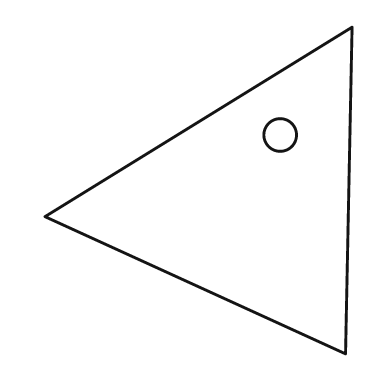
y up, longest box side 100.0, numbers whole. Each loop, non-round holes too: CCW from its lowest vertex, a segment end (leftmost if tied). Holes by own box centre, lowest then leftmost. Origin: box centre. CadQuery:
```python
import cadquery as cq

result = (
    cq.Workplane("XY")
    .moveTo(45.0, -50.0)
    .lineTo(47.0, 50.0)
    .lineTo(-47.0, -8.0)
    .close()
    .moveTo(25.0, 17.0)
    .circle(5.0)
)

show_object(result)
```